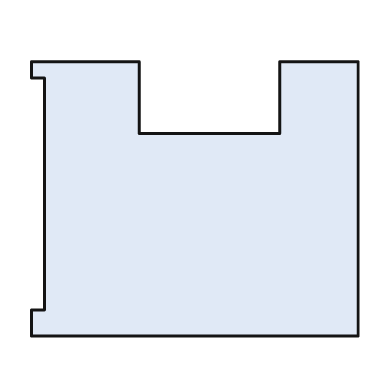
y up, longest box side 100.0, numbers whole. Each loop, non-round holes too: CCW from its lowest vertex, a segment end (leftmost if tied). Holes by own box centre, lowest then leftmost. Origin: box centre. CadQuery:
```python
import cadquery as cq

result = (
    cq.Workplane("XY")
    .moveTo(-50.0, -42.0)
    .lineTo(50.0, -42.0)
    .lineTo(50.0, 42.0)
    .lineTo(26.0, 42.0)
    .lineTo(26.0, 20.0)
    .lineTo(-17.0, 20.0)
    .lineTo(-17.0, 42.0)
    .lineTo(-50.0, 42.0)
    .lineTo(-50.0, 37.0)
    .lineTo(-46.0, 37.0)
    .lineTo(-46.0, -34.0)
    .lineTo(-50.0, -34.0)
    .close()
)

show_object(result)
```